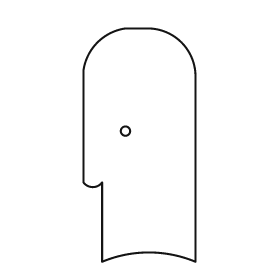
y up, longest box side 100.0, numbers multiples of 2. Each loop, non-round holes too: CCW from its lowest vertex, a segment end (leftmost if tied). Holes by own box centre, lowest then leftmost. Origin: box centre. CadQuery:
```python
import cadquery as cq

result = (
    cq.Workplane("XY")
    .moveTo(-16.0, -50.0)
    .threePointArc((4.0, -46.0), (24.0, -50.0))
    .lineTo(24.0, 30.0)
    .threePointArc((18.0, 44.0), (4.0, 50.0))
    .lineTo(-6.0, 50.0)
    .threePointArc((-18.0, 44.0), (-24.0, 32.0))
    .lineTo(-24.0, -16.0)
    .threePointArc((-20.0, -18.0), (-16.0, -16.0))
    .close()
    .moveTo(-6.0, 6.0)
    .circle(2.0)
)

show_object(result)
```